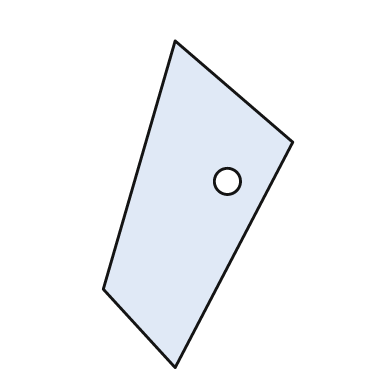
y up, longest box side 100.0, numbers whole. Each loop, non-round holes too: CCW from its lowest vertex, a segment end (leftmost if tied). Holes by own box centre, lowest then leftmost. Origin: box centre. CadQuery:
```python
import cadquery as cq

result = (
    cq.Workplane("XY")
    .moveTo(-7.0, -50.0)
    .lineTo(29.0, 19.0)
    .lineTo(-7.0, 50.0)
    .lineTo(-29.0, -26.0)
    .close()
    .moveTo(9.0, 7.0)
    .circle(4.0)
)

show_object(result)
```